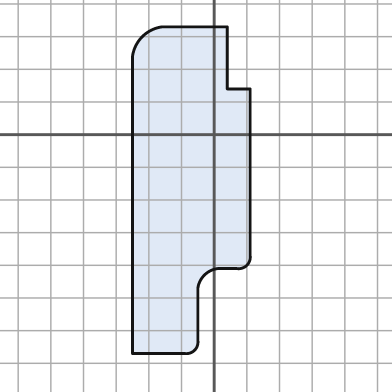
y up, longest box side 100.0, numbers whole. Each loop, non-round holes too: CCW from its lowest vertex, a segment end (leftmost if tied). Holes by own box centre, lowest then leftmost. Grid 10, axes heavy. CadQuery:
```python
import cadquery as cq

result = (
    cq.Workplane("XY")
    .moveTo(-25.0, -67.0)
    .lineTo(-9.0, -67.0)
    .threePointArc((-6.0, -66.0), (-5.0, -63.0))
    .lineTo(-5.0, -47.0)
    .threePointArc((-3.0, -43.0), (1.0, -41.0))
    .lineTo(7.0, -41.0)
    .threePointArc((10.0, -40.0), (11.0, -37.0))
    .lineTo(11.0, 14.0)
    .lineTo(4.0, 14.0)
    .lineTo(4.0, 33.0)
    .lineTo(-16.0, 33.0)
    .threePointArc((-22.0, 30.0), (-25.0, 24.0))
    .close()
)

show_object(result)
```